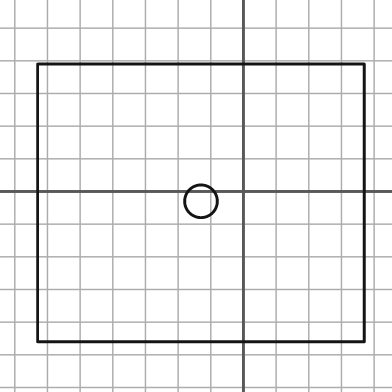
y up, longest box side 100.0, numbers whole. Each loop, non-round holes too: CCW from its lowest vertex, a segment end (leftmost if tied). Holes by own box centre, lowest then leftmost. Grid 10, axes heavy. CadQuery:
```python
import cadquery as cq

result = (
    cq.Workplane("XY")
    .moveTo(-63.0, -46.0)
    .lineTo(37.0, -46.0)
    .lineTo(37.0, 39.0)
    .lineTo(-63.0, 39.0)
    .close()
    .moveTo(-13.0, -3.0)
    .circle(5.0)
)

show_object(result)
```